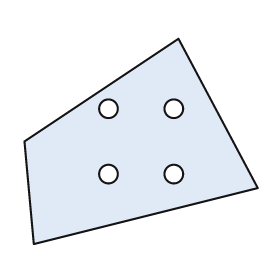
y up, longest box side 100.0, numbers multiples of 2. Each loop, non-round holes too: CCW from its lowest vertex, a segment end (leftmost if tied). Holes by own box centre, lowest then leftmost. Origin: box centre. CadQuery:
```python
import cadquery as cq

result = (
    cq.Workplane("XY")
    .moveTo(-46.0, -44.0)
    .lineTo(50.0, -20.0)
    .lineTo(16.0, 44.0)
    .lineTo(-50.0, 0.0)
    .close()
    .moveTo(-14.0, -14.0)
    .circle(4.0)
    .moveTo(14.0, -14.0)
    .circle(4.0)
    .moveTo(-14.0, 14.0)
    .circle(4.0)
    .moveTo(14.0, 14.0)
    .circle(4.0)
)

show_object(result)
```